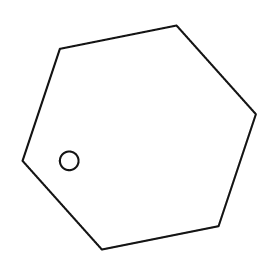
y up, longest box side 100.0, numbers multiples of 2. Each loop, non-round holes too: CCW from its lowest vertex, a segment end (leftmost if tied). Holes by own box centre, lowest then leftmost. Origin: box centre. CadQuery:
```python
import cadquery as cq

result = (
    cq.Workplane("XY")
    .moveTo(-16.0, -48.0)
    .lineTo(34.0, -38.0)
    .lineTo(50.0, 10.0)
    .lineTo(16.0, 48.0)
    .lineTo(-34.0, 38.0)
    .lineTo(-50.0, -10.0)
    .close()
    .moveTo(-30.0, -10.0)
    .circle(4.0)
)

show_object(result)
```